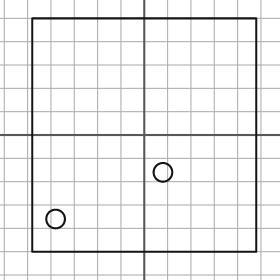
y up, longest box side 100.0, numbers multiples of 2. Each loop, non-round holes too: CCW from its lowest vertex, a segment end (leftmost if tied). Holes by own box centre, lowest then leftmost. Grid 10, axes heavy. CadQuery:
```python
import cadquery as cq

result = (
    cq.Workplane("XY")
    .moveTo(-48.0, -50.0)
    .lineTo(48.0, -50.0)
    .lineTo(48.0, 50.0)
    .lineTo(-48.0, 50.0)
    .close()
    .moveTo(-38.0, -36.0)
    .circle(4.0)
    .moveTo(8.0, -16.0)
    .circle(4.0)
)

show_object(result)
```